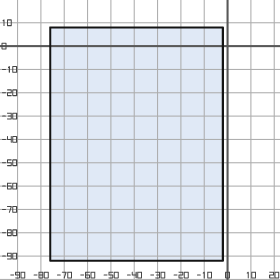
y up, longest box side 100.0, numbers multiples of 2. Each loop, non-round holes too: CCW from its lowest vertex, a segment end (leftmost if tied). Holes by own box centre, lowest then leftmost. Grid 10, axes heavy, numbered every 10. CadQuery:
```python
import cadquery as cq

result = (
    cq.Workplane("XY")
    .moveTo(-76.0, -92.0)
    .lineTo(-2.0, -92.0)
    .lineTo(-2.0, 8.0)
    .lineTo(-76.0, 8.0)
    .close()
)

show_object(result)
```